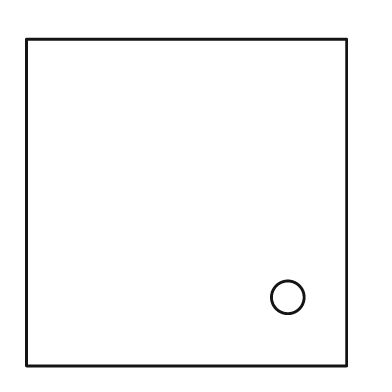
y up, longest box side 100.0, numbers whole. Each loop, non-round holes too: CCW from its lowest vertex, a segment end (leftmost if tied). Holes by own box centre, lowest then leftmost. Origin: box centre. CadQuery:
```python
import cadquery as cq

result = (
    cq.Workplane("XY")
    .moveTo(-49.0, -50.0)
    .lineTo(49.0, -50.0)
    .lineTo(49.0, 50.0)
    .lineTo(-49.0, 50.0)
    .close()
    .moveTo(31.0, -29.0)
    .circle(5.0)
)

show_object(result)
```